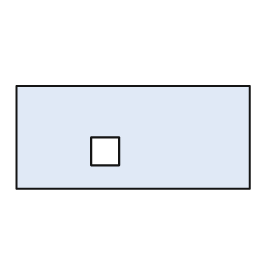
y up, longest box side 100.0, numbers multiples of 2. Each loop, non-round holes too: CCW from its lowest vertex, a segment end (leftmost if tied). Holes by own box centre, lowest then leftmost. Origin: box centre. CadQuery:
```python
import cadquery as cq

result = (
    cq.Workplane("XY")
    .moveTo(-50.0, -22.0)
    .lineTo(50.0, -22.0)
    .lineTo(50.0, 22.0)
    .lineTo(-50.0, 22.0)
    .close()
    .moveTo(-18.0, -12.0)
    .lineTo(-6.0, -12.0)
    .lineTo(-6.0, 0.0)
    .lineTo(-18.0, 0.0)
    .close()
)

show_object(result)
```